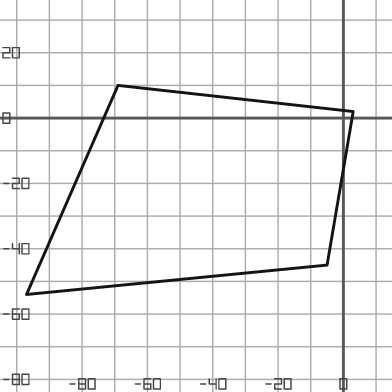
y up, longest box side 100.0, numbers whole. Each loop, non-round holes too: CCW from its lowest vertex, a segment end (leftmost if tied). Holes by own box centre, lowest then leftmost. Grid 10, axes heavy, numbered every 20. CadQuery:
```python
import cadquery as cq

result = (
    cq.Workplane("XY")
    .moveTo(-97.0, -54.0)
    .lineTo(-5.0, -45.0)
    .lineTo(3.0, 2.0)
    .lineTo(-69.0, 10.0)
    .close()
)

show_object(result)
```